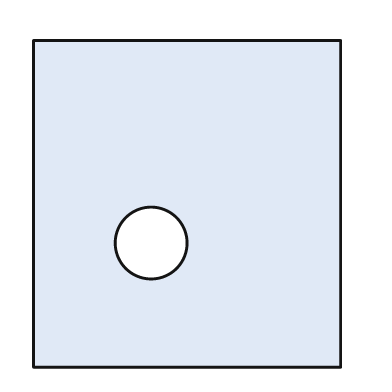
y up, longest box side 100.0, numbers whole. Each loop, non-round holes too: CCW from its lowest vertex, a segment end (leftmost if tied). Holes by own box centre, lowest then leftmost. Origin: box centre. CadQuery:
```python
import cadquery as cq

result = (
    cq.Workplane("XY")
    .moveTo(-47.0, -50.0)
    .lineTo(47.0, -50.0)
    .lineTo(47.0, 50.0)
    .lineTo(-47.0, 50.0)
    .close()
    .moveTo(-11.0, -12.0)
    .circle(11.0)
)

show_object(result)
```